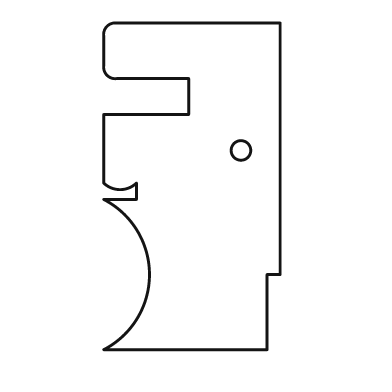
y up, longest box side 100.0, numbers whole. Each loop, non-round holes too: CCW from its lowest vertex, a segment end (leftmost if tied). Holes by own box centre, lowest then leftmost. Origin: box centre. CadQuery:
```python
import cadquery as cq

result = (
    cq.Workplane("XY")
    .moveTo(-27.0, -50.0)
    .lineTo(23.0, -50.0)
    .lineTo(23.0, -27.0)
    .lineTo(27.0, -27.0)
    .lineTo(27.0, 50.0)
    .lineTo(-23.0, 50.0)
    .threePointArc((-26.0, 49.0), (-27.0, 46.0))
    .lineTo(-27.0, 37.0)
    .threePointArc((-26.0, 34.0), (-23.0, 33.0))
    .lineTo(-1.0, 33.0)
    .lineTo(-1.0, 22.0)
    .lineTo(-27.0, 22.0)
    .lineTo(-27.0, 1.0)
    .threePointArc((-22.0, -1.0), (-17.0, 1.0))
    .lineTo(-17.0, -4.0)
    .lineTo(-27.0, -4.0)
    .threePointArc((-13.0, -27.0), (-27.0, -50.0))
    .close()
    .moveTo(15.0, 11.0)
    .circle(3.0)
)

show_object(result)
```